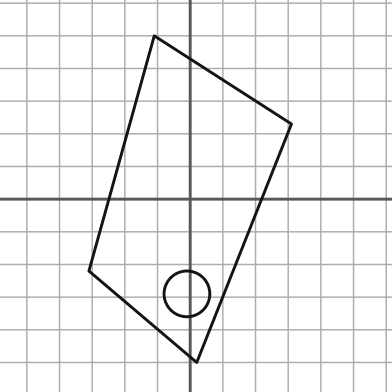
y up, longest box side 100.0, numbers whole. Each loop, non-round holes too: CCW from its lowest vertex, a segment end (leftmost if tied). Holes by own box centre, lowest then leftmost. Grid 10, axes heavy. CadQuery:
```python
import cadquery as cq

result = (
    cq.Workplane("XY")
    .moveTo(2.0, -50.0)
    .lineTo(31.0, 23.0)
    .lineTo(-11.0, 50.0)
    .lineTo(-31.0, -22.0)
    .close()
    .moveTo(-1.0, -29.0)
    .circle(7.0)
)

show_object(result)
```